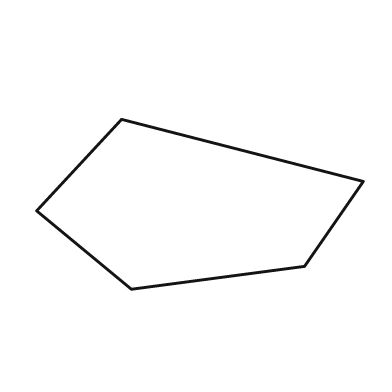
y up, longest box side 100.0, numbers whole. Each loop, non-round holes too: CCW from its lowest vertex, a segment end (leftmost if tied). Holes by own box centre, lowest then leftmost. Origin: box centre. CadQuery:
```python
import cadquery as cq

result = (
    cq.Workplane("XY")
    .moveTo(-21.0, -26.0)
    .lineTo(32.0, -19.0)
    .lineTo(50.0, 7.0)
    .lineTo(-24.0, 26.0)
    .lineTo(-50.0, -2.0)
    .close()
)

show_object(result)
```